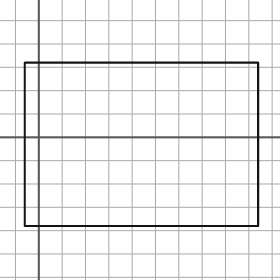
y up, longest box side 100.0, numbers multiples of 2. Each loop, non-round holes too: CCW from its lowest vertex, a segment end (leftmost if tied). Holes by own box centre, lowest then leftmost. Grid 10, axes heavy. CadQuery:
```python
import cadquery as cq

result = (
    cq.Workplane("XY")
    .moveTo(-6.0, -38.0)
    .lineTo(94.0, -38.0)
    .lineTo(94.0, 32.0)
    .lineTo(-6.0, 32.0)
    .close()
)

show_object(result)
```